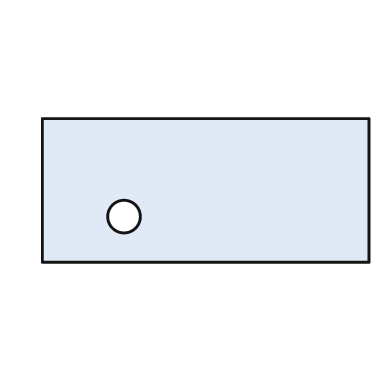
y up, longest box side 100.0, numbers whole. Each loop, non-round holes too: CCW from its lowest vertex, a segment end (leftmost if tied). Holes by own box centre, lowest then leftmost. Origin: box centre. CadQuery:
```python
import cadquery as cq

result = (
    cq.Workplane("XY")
    .moveTo(-50.0, -22.0)
    .lineTo(50.0, -22.0)
    .lineTo(50.0, 22.0)
    .lineTo(-50.0, 22.0)
    .close()
    .moveTo(-25.0, -8.0)
    .circle(5.0)
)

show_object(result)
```